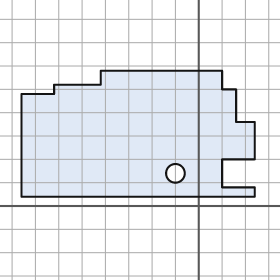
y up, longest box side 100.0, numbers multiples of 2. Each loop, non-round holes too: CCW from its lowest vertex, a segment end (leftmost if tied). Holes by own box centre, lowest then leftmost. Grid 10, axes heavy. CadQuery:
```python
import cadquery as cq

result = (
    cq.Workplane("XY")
    .moveTo(-76.0, 4.0)
    .lineTo(24.0, 4.0)
    .lineTo(24.0, 8.0)
    .lineTo(10.0, 8.0)
    .lineTo(10.0, 20.0)
    .lineTo(24.0, 20.0)
    .lineTo(24.0, 36.0)
    .lineTo(16.0, 36.0)
    .lineTo(16.0, 50.0)
    .lineTo(10.0, 50.0)
    .lineTo(10.0, 58.0)
    .lineTo(-42.0, 58.0)
    .lineTo(-42.0, 52.0)
    .lineTo(-62.0, 52.0)
    .lineTo(-62.0, 48.0)
    .lineTo(-76.0, 48.0)
    .close()
    .moveTo(-10.0, 14.0)
    .circle(4.0)
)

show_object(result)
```